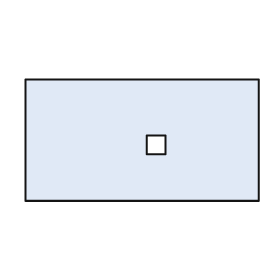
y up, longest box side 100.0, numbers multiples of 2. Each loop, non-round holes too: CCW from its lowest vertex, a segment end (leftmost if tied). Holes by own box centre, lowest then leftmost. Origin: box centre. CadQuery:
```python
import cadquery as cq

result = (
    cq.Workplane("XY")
    .moveTo(-50.0, -26.0)
    .lineTo(50.0, -26.0)
    .lineTo(50.0, 26.0)
    .lineTo(-50.0, 26.0)
    .close()
    .moveTo(2.0, -6.0)
    .lineTo(10.0, -6.0)
    .lineTo(10.0, 2.0)
    .lineTo(2.0, 2.0)
    .close()
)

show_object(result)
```